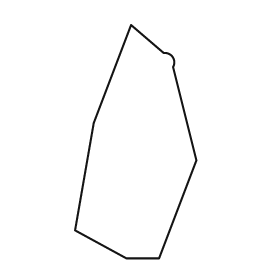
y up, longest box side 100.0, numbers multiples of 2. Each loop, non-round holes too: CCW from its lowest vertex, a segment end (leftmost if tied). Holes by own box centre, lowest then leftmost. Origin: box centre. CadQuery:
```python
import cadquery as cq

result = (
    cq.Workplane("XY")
    .moveTo(-4.0, -50.0)
    .lineTo(10.0, -50.0)
    .lineTo(26.0, -8.0)
    .lineTo(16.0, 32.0)
    .threePointArc((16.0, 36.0), (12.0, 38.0))
    .lineTo(-2.0, 50.0)
    .lineTo(-18.0, 8.0)
    .lineTo(-26.0, -38.0)
    .close()
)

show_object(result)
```